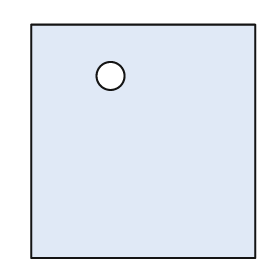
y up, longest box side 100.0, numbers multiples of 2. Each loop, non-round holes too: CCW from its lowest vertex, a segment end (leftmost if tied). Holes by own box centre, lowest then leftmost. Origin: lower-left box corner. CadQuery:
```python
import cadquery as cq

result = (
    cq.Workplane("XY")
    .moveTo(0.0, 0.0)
    .lineTo(96.0, 0.0)
    .lineTo(96.0, 100.0)
    .lineTo(0.0, 100.0)
    .close()
    .moveTo(34.0, 78.0)
    .circle(6.0)
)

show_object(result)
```